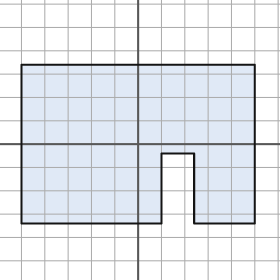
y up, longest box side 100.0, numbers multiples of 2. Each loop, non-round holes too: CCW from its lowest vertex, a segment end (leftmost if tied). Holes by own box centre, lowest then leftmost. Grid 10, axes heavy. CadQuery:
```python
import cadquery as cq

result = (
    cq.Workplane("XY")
    .moveTo(-50.0, -34.0)
    .lineTo(10.0, -34.0)
    .lineTo(10.0, -4.0)
    .lineTo(24.0, -4.0)
    .lineTo(24.0, -34.0)
    .lineTo(50.0, -34.0)
    .lineTo(50.0, 34.0)
    .lineTo(-50.0, 34.0)
    .close()
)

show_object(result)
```